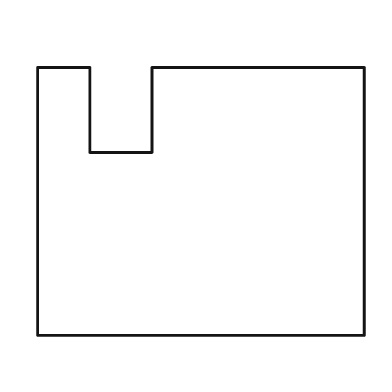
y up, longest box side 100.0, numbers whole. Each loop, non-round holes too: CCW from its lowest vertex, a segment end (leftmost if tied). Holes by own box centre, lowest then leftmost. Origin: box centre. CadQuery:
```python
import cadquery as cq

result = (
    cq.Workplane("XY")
    .moveTo(-50.0, -41.0)
    .lineTo(50.0, -41.0)
    .lineTo(50.0, 41.0)
    .lineTo(-15.0, 41.0)
    .lineTo(-15.0, 15.0)
    .lineTo(-34.0, 15.0)
    .lineTo(-34.0, 41.0)
    .lineTo(-50.0, 41.0)
    .close()
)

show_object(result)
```